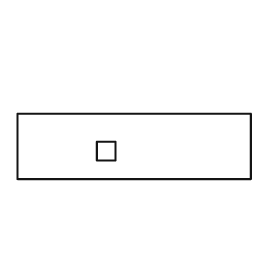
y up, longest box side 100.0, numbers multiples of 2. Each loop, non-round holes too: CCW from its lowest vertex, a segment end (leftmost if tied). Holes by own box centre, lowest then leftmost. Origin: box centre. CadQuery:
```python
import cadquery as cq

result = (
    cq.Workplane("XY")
    .moveTo(-50.0, -14.0)
    .lineTo(50.0, -14.0)
    .lineTo(50.0, 14.0)
    .lineTo(-50.0, 14.0)
    .close()
    .moveTo(-16.0, -6.0)
    .lineTo(-8.0, -6.0)
    .lineTo(-8.0, 2.0)
    .lineTo(-16.0, 2.0)
    .close()
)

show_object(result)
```